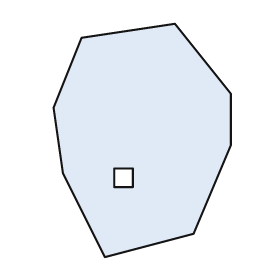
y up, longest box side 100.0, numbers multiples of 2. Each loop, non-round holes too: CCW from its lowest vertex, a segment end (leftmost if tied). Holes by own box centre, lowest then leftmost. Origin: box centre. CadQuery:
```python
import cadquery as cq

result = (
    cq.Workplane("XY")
    .moveTo(-16.0, -50.0)
    .lineTo(22.0, -40.0)
    .lineTo(38.0, -2.0)
    .lineTo(38.0, 20.0)
    .lineTo(14.0, 50.0)
    .lineTo(-26.0, 44.0)
    .lineTo(-38.0, 14.0)
    .lineTo(-34.0, -14.0)
    .close()
    .moveTo(-12.0, -20.0)
    .lineTo(-4.0, -20.0)
    .lineTo(-4.0, -12.0)
    .lineTo(-12.0, -12.0)
    .close()
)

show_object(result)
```